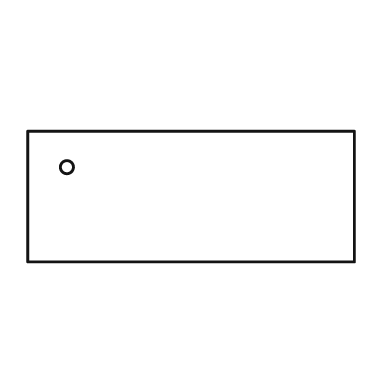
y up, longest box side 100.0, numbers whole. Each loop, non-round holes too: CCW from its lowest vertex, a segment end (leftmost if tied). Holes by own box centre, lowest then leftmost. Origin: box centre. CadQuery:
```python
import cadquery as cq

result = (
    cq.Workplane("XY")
    .moveTo(-50.0, -20.0)
    .lineTo(50.0, -20.0)
    .lineTo(50.0, 20.0)
    .lineTo(-50.0, 20.0)
    .close()
    .moveTo(-38.0, 9.0)
    .circle(2.0)
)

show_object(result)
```